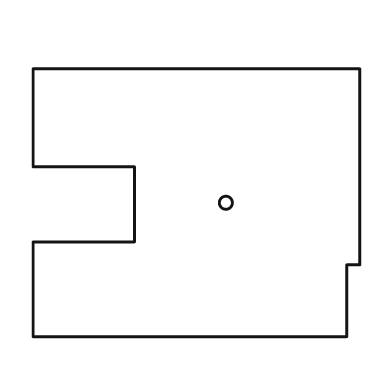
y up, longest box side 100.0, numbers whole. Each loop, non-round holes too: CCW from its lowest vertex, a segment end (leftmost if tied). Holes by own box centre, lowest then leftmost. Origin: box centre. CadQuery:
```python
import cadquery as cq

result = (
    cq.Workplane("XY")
    .moveTo(-50.0, -41.0)
    .lineTo(46.0, -41.0)
    .lineTo(46.0, -19.0)
    .lineTo(50.0, -19.0)
    .lineTo(50.0, 41.0)
    .lineTo(-50.0, 41.0)
    .lineTo(-50.0, 11.0)
    .lineTo(-19.0, 11.0)
    .lineTo(-19.0, -12.0)
    .lineTo(-50.0, -12.0)
    .close()
    .moveTo(9.0, 0.0)
    .circle(2.0)
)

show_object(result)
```